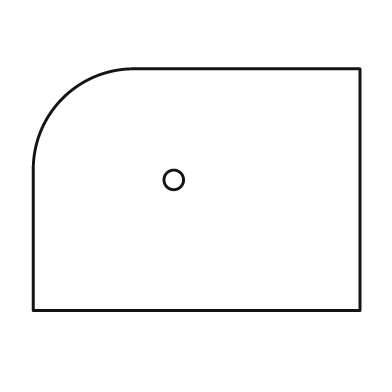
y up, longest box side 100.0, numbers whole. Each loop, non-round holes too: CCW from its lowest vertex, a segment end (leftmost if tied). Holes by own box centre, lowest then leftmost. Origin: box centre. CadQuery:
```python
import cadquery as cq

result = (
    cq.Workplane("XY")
    .moveTo(-50.0, -37.0)
    .lineTo(50.0, -37.0)
    .lineTo(50.0, 37.0)
    .lineTo(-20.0, 37.0)
    .threePointArc((-41.0, 28.0), (-50.0, 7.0))
    .close()
    .moveTo(-7.0, 3.0)
    .circle(3.0)
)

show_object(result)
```